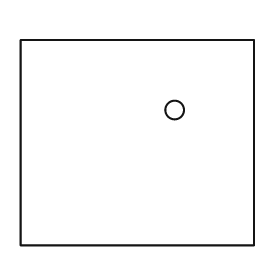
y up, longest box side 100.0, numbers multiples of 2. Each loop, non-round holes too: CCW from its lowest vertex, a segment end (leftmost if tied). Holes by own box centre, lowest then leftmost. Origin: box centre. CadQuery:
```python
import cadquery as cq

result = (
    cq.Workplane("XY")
    .moveTo(-50.0, -44.0)
    .lineTo(50.0, -44.0)
    .lineTo(50.0, 44.0)
    .lineTo(-50.0, 44.0)
    .close()
    .moveTo(16.0, 14.0)
    .circle(4.0)
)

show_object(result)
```